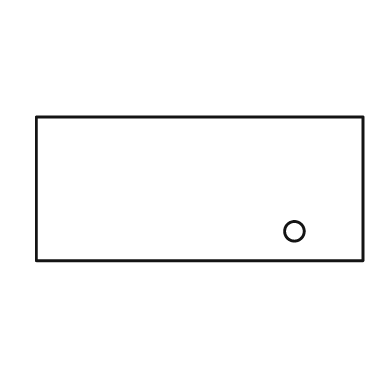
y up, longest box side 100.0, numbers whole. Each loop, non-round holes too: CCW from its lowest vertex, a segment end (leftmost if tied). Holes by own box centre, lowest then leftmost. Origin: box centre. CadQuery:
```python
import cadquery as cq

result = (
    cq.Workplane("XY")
    .moveTo(-50.0, -22.0)
    .lineTo(50.0, -22.0)
    .lineTo(50.0, 22.0)
    .lineTo(-50.0, 22.0)
    .close()
    .moveTo(29.0, -13.0)
    .circle(3.0)
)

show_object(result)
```